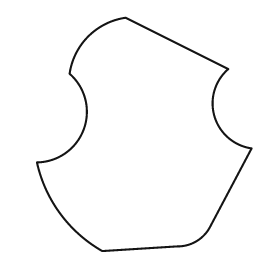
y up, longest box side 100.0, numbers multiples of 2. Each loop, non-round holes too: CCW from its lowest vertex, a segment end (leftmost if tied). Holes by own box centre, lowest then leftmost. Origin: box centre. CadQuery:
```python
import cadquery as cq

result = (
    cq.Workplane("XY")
    .moveTo(-18.0, -50.0)
    .lineTo(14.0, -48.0)
    .threePointArc((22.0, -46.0), (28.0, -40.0))
    .lineTo(46.0, -6.0)
    .threePointArc((30.0, 8.0), (36.0, 28.0))
    .lineTo(-8.0, 50.0)
    .threePointArc((-24.0, 42.0), (-32.0, 26.0))
    .threePointArc((-26.0, 2.0), (-46.0, -12.0))
    .threePointArc((-36.0, -34.0), (-18.0, -50.0))
    .close()
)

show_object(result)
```